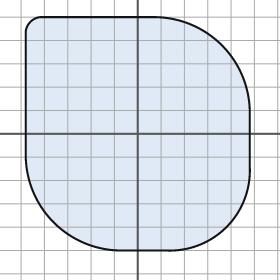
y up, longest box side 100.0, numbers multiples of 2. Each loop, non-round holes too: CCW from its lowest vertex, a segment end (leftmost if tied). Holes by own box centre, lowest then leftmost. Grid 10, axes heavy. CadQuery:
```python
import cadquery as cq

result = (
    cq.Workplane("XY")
    .moveTo(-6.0, -50.0)
    .lineTo(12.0, -50.0)
    .threePointArc((38.0, -40.0), (48.0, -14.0))
    .lineTo(48.0, 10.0)
    .threePointArc((36.0, 38.0), (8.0, 50.0))
    .lineTo(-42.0, 50.0)
    .threePointArc((-46.0, 48.0), (-48.0, 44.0))
    .lineTo(-48.0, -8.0)
    .threePointArc((-36.0, -38.0), (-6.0, -50.0))
    .close()
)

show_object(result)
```